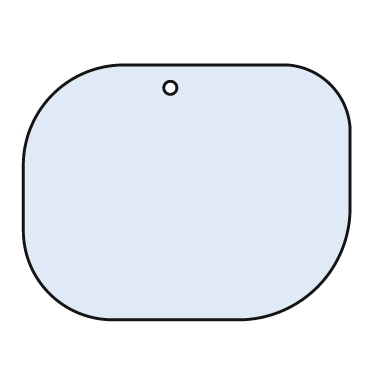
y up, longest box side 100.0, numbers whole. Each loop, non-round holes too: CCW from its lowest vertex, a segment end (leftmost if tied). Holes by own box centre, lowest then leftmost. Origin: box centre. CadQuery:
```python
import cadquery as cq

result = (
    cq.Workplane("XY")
    .moveTo(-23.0, -39.0)
    .lineTo(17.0, -39.0)
    .threePointArc((40.0, -29.0), (50.0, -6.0))
    .lineTo(50.0, 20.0)
    .threePointArc((44.0, 33.0), (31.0, 39.0))
    .lineTo(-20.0, 39.0)
    .threePointArc((-41.0, 30.0), (-50.0, 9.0))
    .lineTo(-50.0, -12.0)
    .threePointArc((-42.0, -31.0), (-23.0, -39.0))
    .close()
    .moveTo(-5.0, 32.0)
    .circle(2.0)
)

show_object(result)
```